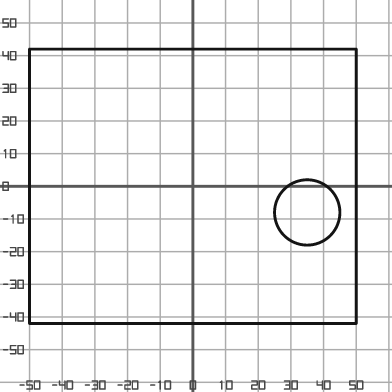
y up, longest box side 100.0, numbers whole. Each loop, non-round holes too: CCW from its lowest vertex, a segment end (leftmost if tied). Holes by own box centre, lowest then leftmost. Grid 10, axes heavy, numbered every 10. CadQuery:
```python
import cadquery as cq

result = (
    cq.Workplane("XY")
    .moveTo(-50.0, -42.0)
    .lineTo(50.0, -42.0)
    .lineTo(50.0, 42.0)
    .lineTo(-50.0, 42.0)
    .close()
    .moveTo(35.0, -8.0)
    .circle(10.0)
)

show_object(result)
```